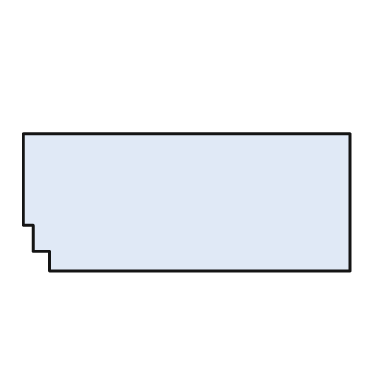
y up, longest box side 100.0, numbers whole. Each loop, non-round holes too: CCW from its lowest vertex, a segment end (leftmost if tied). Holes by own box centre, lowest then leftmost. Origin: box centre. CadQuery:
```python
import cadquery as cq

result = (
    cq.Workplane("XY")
    .moveTo(-42.0, -21.0)
    .lineTo(50.0, -21.0)
    .lineTo(50.0, 21.0)
    .lineTo(-50.0, 21.0)
    .lineTo(-50.0, -7.0)
    .lineTo(-47.0, -7.0)
    .lineTo(-47.0, -15.0)
    .lineTo(-42.0, -15.0)
    .close()
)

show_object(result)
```